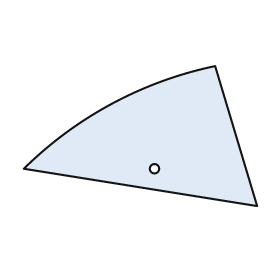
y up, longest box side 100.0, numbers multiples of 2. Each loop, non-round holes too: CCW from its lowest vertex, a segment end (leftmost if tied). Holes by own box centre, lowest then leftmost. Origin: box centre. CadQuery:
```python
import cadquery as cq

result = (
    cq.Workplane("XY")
    .moveTo(50.0, -30.0)
    .lineTo(32.0, 30.0)
    .threePointArc((-12.0, 14.0), (-50.0, -14.0))
    .close()
    .moveTo(6.0, -14.0)
    .circle(2.0)
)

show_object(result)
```